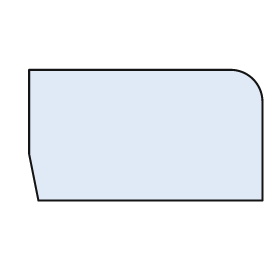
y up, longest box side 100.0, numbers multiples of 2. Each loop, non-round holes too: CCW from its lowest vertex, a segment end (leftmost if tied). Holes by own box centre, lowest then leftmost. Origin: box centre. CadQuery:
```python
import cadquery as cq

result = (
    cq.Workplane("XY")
    .moveTo(-46.0, -28.0)
    .lineTo(50.0, -28.0)
    .lineTo(50.0, 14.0)
    .threePointArc((46.0, 24.0), (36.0, 28.0))
    .lineTo(-50.0, 28.0)
    .lineTo(-50.0, -8.0)
    .close()
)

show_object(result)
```